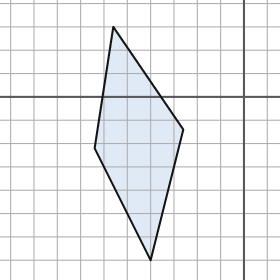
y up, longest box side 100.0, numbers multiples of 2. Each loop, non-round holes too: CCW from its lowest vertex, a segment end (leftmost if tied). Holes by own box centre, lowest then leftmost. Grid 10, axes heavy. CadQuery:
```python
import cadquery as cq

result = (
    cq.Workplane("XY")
    .moveTo(-40.0, -70.0)
    .lineTo(-26.0, -14.0)
    .lineTo(-56.0, 30.0)
    .lineTo(-64.0, -22.0)
    .close()
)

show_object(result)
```